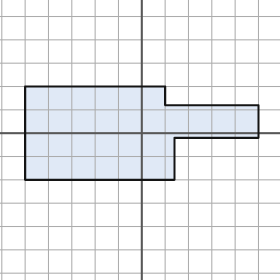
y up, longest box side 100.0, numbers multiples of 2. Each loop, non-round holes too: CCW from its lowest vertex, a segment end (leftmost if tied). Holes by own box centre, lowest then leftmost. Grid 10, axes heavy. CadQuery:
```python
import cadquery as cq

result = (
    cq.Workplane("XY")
    .moveTo(-50.0, -20.0)
    .lineTo(14.0, -20.0)
    .lineTo(14.0, -2.0)
    .lineTo(50.0, -2.0)
    .lineTo(50.0, 12.0)
    .lineTo(10.0, 12.0)
    .lineTo(10.0, 20.0)
    .lineTo(-50.0, 20.0)
    .close()
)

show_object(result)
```